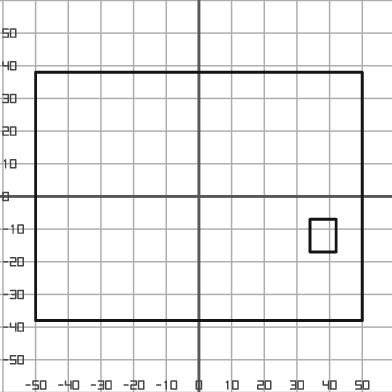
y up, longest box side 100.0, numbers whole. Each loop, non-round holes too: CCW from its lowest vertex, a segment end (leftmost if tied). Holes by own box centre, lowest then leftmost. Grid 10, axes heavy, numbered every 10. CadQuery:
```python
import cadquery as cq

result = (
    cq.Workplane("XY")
    .moveTo(-50.0, -38.0)
    .lineTo(50.0, -38.0)
    .lineTo(50.0, 38.0)
    .lineTo(-50.0, 38.0)
    .close()
    .moveTo(34.0, -17.0)
    .lineTo(42.0, -17.0)
    .lineTo(42.0, -7.0)
    .lineTo(34.0, -7.0)
    .close()
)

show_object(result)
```